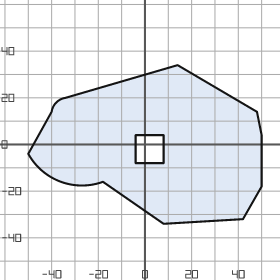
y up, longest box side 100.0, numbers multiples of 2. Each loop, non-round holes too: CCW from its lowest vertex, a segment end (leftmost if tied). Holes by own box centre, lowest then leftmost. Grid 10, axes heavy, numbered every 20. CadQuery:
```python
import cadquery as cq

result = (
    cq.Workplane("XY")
    .moveTo(8.0, -34.0)
    .lineTo(42.0, -32.0)
    .lineTo(50.0, -18.0)
    .lineTo(50.0, 4.0)
    .lineTo(48.0, 14.0)
    .lineTo(14.0, 34.0)
    .lineTo(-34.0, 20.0)
    .threePointArc((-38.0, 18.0), (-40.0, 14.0))
    .lineTo(-50.0, -4.0)
    .threePointArc((-36.0, -16.0), (-18.0, -16.0))
    .close()
    .moveTo(-4.0, -8.0)
    .lineTo(8.0, -8.0)
    .lineTo(8.0, 4.0)
    .lineTo(-4.0, 4.0)
    .close()
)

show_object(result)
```